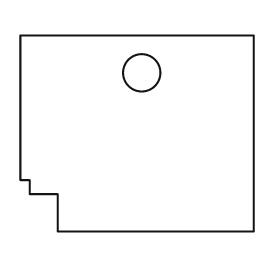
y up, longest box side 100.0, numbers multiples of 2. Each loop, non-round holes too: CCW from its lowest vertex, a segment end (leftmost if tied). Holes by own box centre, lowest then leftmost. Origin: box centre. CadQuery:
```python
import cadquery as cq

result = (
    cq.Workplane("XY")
    .moveTo(-34.0, -42.0)
    .lineTo(50.0, -42.0)
    .lineTo(50.0, 42.0)
    .lineTo(-50.0, 42.0)
    .lineTo(-50.0, -20.0)
    .lineTo(-46.0, -20.0)
    .lineTo(-46.0, -26.0)
    .lineTo(-34.0, -26.0)
    .close()
    .moveTo(2.0, 26.0)
    .circle(8.0)
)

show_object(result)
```